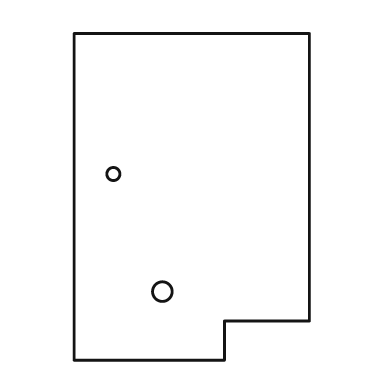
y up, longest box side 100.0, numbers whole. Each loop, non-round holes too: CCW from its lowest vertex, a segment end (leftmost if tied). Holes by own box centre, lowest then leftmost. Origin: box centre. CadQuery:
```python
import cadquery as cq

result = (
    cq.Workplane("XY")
    .moveTo(-36.0, -50.0)
    .lineTo(10.0, -50.0)
    .lineTo(10.0, -38.0)
    .lineTo(36.0, -38.0)
    .lineTo(36.0, 50.0)
    .lineTo(-36.0, 50.0)
    .close()
    .moveTo(-9.0, -29.0)
    .circle(3.0)
    .moveTo(-24.0, 7.0)
    .circle(2.0)
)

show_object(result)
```